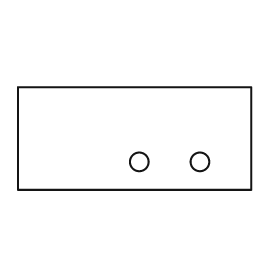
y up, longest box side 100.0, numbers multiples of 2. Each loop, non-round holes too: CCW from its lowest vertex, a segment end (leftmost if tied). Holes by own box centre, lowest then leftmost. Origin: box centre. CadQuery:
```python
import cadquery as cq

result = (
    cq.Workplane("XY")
    .moveTo(-50.0, -22.0)
    .lineTo(50.0, -22.0)
    .lineTo(50.0, 22.0)
    .lineTo(-50.0, 22.0)
    .close()
    .moveTo(2.0, -10.0)
    .circle(4.0)
    .moveTo(28.0, -10.0)
    .circle(4.0)
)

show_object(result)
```